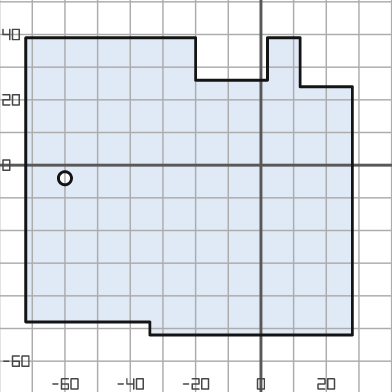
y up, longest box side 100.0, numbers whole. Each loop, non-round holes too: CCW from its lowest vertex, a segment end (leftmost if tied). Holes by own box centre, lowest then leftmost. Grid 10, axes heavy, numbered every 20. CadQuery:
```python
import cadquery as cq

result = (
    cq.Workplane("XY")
    .moveTo(-34.0, -52.0)
    .lineTo(28.0, -52.0)
    .lineTo(28.0, 24.0)
    .lineTo(12.0, 24.0)
    .lineTo(12.0, 39.0)
    .lineTo(2.0, 39.0)
    .lineTo(2.0, 26.0)
    .lineTo(-20.0, 26.0)
    .lineTo(-20.0, 39.0)
    .lineTo(-72.0, 39.0)
    .lineTo(-72.0, -48.0)
    .lineTo(-34.0, -48.0)
    .close()
    .moveTo(-60.0, -4.0)
    .circle(2.0)
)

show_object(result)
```